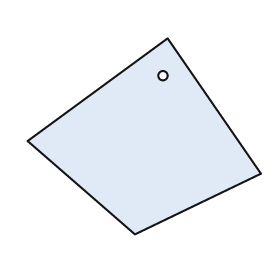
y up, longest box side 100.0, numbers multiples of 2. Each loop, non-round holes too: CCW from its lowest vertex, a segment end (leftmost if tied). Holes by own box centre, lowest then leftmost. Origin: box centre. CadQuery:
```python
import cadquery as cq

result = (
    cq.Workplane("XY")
    .moveTo(-4.0, -42.0)
    .lineTo(50.0, -16.0)
    .lineTo(10.0, 42.0)
    .lineTo(-50.0, -2.0)
    .close()
    .moveTo(8.0, 26.0)
    .circle(2.0)
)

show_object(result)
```